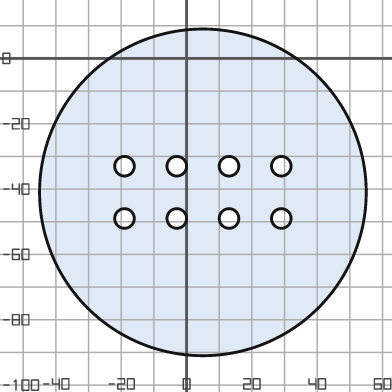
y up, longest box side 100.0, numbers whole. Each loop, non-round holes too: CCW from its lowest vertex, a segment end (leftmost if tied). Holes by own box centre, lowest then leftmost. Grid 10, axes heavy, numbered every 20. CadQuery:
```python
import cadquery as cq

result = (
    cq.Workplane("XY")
    .moveTo(5.0, -41.0)
    .circle(50.0)
    .moveTo(-19.0, -49.0)
    .circle(3.0)
    .moveTo(-3.0, -49.0)
    .circle(3.0)
    .moveTo(13.0, -49.0)
    .circle(3.0)
    .moveTo(29.0, -49.0)
    .circle(3.0)
    .moveTo(-19.0, -33.0)
    .circle(3.0)
    .moveTo(-3.0, -33.0)
    .circle(3.0)
    .moveTo(13.0, -33.0)
    .circle(3.0)
    .moveTo(29.0, -33.0)
    .circle(3.0)
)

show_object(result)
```